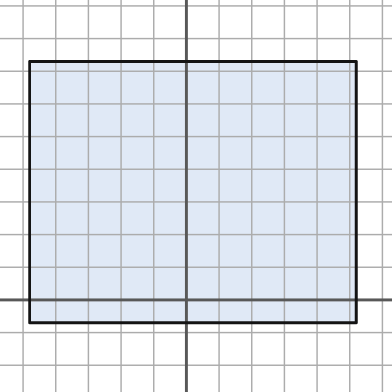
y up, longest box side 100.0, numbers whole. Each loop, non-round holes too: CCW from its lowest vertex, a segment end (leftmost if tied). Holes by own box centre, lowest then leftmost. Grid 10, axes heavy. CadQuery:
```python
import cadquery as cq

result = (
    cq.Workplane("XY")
    .moveTo(-48.0, -7.0)
    .lineTo(52.0, -7.0)
    .lineTo(52.0, 73.0)
    .lineTo(-48.0, 73.0)
    .close()
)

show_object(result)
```